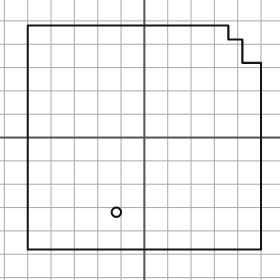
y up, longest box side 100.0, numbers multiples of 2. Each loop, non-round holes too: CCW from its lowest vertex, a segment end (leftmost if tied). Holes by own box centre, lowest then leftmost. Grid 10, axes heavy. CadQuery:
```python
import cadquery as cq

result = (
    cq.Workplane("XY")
    .moveTo(-50.0, -48.0)
    .lineTo(50.0, -48.0)
    .lineTo(50.0, 32.0)
    .lineTo(42.0, 32.0)
    .lineTo(42.0, 42.0)
    .lineTo(36.0, 42.0)
    .lineTo(36.0, 48.0)
    .lineTo(-50.0, 48.0)
    .close()
    .moveTo(-12.0, -32.0)
    .circle(2.0)
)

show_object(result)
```